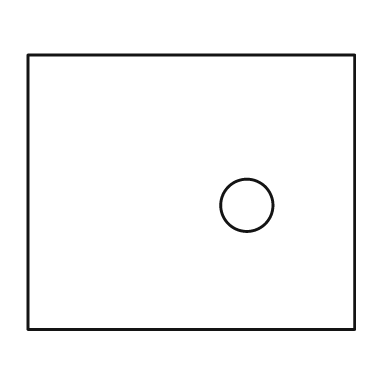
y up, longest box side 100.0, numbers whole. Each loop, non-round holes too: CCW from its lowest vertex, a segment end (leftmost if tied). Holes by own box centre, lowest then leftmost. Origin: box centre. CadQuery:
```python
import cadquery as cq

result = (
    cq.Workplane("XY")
    .moveTo(-50.0, -42.0)
    .lineTo(50.0, -42.0)
    .lineTo(50.0, 42.0)
    .lineTo(-50.0, 42.0)
    .close()
    .moveTo(17.0, -4.0)
    .circle(8.0)
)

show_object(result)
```